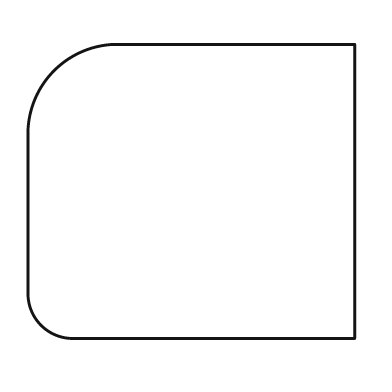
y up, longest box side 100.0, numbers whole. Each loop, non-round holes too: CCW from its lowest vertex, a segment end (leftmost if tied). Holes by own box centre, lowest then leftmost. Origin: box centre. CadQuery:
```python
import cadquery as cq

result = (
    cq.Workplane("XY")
    .moveTo(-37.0, -45.0)
    .lineTo(50.0, -45.0)
    .lineTo(50.0, 45.0)
    .lineTo(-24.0, 45.0)
    .threePointArc((-42.0, 37.0), (-50.0, 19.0))
    .lineTo(-50.0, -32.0)
    .threePointArc((-46.0, -41.0), (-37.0, -45.0))
    .close()
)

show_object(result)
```